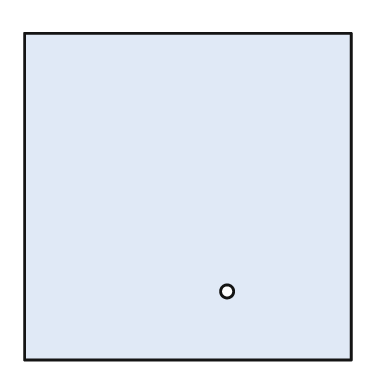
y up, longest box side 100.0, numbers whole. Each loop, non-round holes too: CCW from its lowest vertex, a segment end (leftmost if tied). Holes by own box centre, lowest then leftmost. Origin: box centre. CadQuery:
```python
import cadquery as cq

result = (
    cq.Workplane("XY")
    .moveTo(-50.0, -50.0)
    .lineTo(50.0, -50.0)
    .lineTo(50.0, 50.0)
    .lineTo(-50.0, 50.0)
    .close()
    .moveTo(12.0, -29.0)
    .circle(2.0)
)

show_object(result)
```